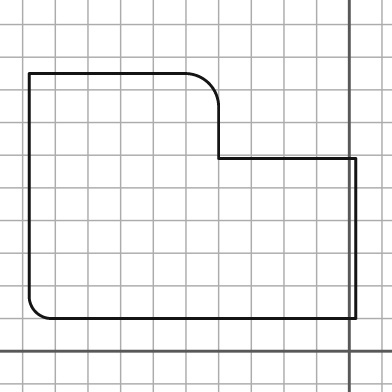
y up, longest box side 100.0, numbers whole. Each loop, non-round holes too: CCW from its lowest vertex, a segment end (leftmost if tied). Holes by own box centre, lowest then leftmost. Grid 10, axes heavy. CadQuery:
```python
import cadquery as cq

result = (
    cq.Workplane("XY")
    .moveTo(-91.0, 10.0)
    .lineTo(2.0, 10.0)
    .lineTo(2.0, 59.0)
    .lineTo(-40.0, 59.0)
    .lineTo(-40.0, 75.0)
    .threePointArc((-43.0, 82.0), (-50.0, 85.0))
    .lineTo(-98.0, 85.0)
    .lineTo(-98.0, 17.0)
    .threePointArc((-96.0, 12.0), (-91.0, 10.0))
    .close()
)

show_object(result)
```